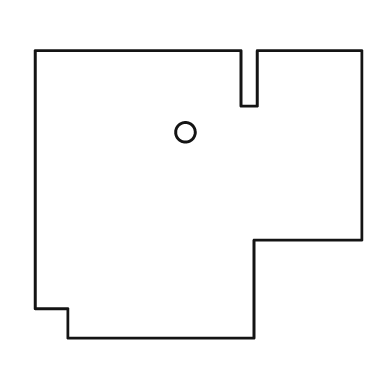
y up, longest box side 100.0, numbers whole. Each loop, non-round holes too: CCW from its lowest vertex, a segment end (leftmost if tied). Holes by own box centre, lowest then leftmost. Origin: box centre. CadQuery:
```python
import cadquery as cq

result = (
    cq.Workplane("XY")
    .moveTo(-40.0, -44.0)
    .lineTo(17.0, -44.0)
    .lineTo(17.0, -14.0)
    .lineTo(50.0, -14.0)
    .lineTo(50.0, 44.0)
    .lineTo(18.0, 44.0)
    .lineTo(18.0, 27.0)
    .lineTo(13.0, 27.0)
    .lineTo(13.0, 44.0)
    .lineTo(-50.0, 44.0)
    .lineTo(-50.0, -35.0)
    .lineTo(-40.0, -35.0)
    .close()
    .moveTo(-4.0, 19.0)
    .circle(3.0)
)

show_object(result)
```